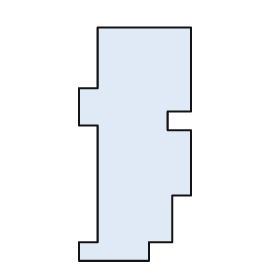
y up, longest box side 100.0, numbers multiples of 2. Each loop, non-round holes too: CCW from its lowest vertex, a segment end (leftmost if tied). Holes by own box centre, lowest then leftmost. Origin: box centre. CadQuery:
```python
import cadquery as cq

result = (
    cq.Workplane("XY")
    .moveTo(-24.0, -50.0)
    .lineTo(6.0, -50.0)
    .lineTo(6.0, -42.0)
    .lineTo(16.0, -42.0)
    .lineTo(16.0, -22.0)
    .lineTo(24.0, -22.0)
    .lineTo(24.0, 6.0)
    .lineTo(14.0, 6.0)
    .lineTo(14.0, 14.0)
    .lineTo(24.0, 14.0)
    .lineTo(24.0, 50.0)
    .lineTo(-16.0, 50.0)
    .lineTo(-16.0, 24.0)
    .lineTo(-24.0, 24.0)
    .lineTo(-24.0, 8.0)
    .lineTo(-16.0, 8.0)
    .lineTo(-16.0, -42.0)
    .lineTo(-24.0, -42.0)
    .close()
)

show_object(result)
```